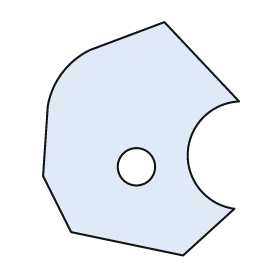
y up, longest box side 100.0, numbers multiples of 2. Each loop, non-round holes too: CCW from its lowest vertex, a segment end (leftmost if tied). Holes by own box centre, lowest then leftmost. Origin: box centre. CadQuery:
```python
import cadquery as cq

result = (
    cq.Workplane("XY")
    .moveTo(18.0, -50.0)
    .lineTo(40.0, -30.0)
    .threePointArc((20.0, -6.0), (42.0, 16.0))
    .lineTo(10.0, 50.0)
    .lineTo(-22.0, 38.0)
    .threePointArc((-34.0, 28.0), (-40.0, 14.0))
    .lineTo(-42.0, -16.0)
    .lineTo(-30.0, -40.0)
    .close()
    .moveTo(-2.0, -12.0)
    .circle(8.0)
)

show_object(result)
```